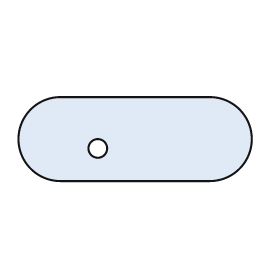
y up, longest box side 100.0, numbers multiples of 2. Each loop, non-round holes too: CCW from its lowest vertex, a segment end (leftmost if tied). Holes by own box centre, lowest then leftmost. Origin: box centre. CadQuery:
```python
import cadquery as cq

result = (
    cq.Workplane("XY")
    .moveTo(-32.0, -18.0)
    .lineTo(32.0, -18.0)
    .threePointArc((50.0, 0.0), (32.0, 18.0))
    .lineTo(-32.0, 18.0)
    .threePointArc((-50.0, 0.0), (-32.0, -18.0))
    .close()
    .moveTo(-16.0, -4.0)
    .circle(4.0)
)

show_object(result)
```